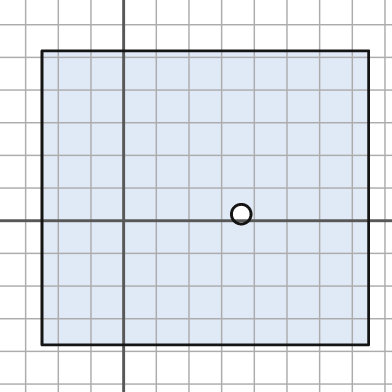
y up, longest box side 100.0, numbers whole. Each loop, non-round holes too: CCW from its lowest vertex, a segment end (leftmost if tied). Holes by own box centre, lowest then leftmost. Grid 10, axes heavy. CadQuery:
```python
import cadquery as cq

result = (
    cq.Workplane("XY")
    .moveTo(-25.0, -38.0)
    .lineTo(75.0, -38.0)
    .lineTo(75.0, 52.0)
    .lineTo(-25.0, 52.0)
    .close()
    .moveTo(36.0, 2.0)
    .circle(3.0)
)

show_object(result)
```